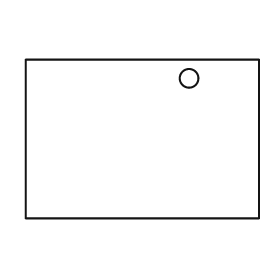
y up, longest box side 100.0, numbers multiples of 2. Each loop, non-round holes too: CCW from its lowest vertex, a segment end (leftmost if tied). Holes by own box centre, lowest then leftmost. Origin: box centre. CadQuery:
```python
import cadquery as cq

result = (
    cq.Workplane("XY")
    .moveTo(-50.0, -34.0)
    .lineTo(50.0, -34.0)
    .lineTo(50.0, 34.0)
    .lineTo(-50.0, 34.0)
    .close()
    .moveTo(20.0, 26.0)
    .circle(4.0)
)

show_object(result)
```